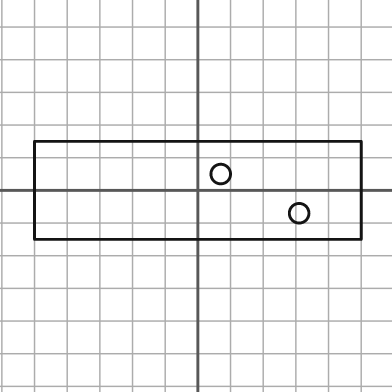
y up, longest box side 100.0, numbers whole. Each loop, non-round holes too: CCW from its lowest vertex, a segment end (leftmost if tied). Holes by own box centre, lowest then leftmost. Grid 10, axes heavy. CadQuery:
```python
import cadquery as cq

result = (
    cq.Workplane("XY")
    .moveTo(-50.0, -15.0)
    .lineTo(50.0, -15.0)
    .lineTo(50.0, 15.0)
    .lineTo(-50.0, 15.0)
    .close()
    .moveTo(31.0, -7.0)
    .circle(3.0)
    .moveTo(7.0, 5.0)
    .circle(3.0)
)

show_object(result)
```